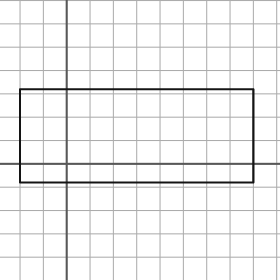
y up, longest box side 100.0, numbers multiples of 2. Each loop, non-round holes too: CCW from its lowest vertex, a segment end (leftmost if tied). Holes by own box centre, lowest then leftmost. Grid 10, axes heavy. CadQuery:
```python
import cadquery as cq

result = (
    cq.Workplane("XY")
    .moveTo(-20.0, -8.0)
    .lineTo(80.0, -8.0)
    .lineTo(80.0, 32.0)
    .lineTo(-20.0, 32.0)
    .close()
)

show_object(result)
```